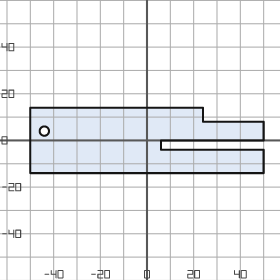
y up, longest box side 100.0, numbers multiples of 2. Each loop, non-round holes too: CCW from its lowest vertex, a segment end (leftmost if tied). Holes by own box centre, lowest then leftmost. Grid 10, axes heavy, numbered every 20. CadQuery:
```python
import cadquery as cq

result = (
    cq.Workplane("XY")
    .moveTo(-50.0, -14.0)
    .lineTo(50.0, -14.0)
    .lineTo(50.0, -4.0)
    .lineTo(6.0, -4.0)
    .lineTo(6.0, 0.0)
    .lineTo(50.0, 0.0)
    .lineTo(50.0, 8.0)
    .lineTo(24.0, 8.0)
    .lineTo(24.0, 14.0)
    .lineTo(-50.0, 14.0)
    .close()
    .moveTo(-44.0, 4.0)
    .circle(2.0)
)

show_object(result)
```